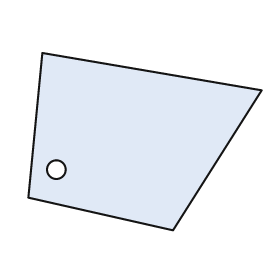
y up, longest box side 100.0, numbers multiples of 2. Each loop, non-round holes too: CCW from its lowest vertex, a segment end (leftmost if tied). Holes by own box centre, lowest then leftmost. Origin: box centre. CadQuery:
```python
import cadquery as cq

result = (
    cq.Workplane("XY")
    .moveTo(12.0, -38.0)
    .lineTo(50.0, 22.0)
    .lineTo(-44.0, 38.0)
    .lineTo(-50.0, -24.0)
    .close()
    .moveTo(-38.0, -12.0)
    .circle(4.0)
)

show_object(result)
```